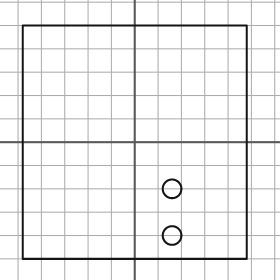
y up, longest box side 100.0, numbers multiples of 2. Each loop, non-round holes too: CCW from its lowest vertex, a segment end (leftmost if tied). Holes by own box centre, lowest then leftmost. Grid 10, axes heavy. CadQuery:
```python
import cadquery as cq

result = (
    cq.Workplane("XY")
    .moveTo(-48.0, -50.0)
    .lineTo(48.0, -50.0)
    .lineTo(48.0, 50.0)
    .lineTo(-48.0, 50.0)
    .close()
    .moveTo(16.0, -40.0)
    .circle(4.0)
    .moveTo(16.0, -20.0)
    .circle(4.0)
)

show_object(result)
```